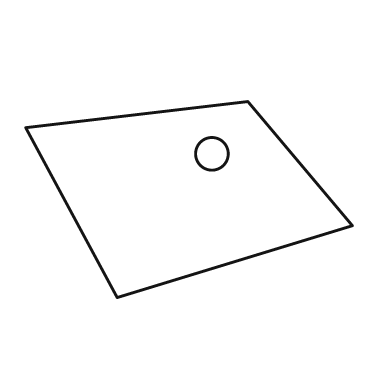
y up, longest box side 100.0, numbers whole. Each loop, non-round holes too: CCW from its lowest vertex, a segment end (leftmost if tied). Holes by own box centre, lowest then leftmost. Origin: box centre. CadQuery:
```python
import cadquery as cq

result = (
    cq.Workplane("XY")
    .moveTo(-22.0, -30.0)
    .lineTo(50.0, -8.0)
    .lineTo(18.0, 30.0)
    .lineTo(-50.0, 22.0)
    .close()
    .moveTo(7.0, 14.0)
    .circle(5.0)
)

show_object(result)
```